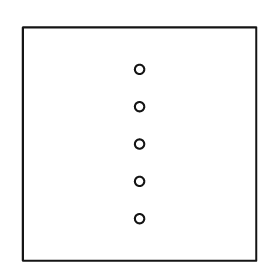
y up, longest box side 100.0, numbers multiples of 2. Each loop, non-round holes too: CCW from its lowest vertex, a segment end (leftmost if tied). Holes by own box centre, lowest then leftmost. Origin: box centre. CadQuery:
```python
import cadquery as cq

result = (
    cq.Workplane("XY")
    .moveTo(-50.0, -50.0)
    .lineTo(50.0, -50.0)
    .lineTo(50.0, 50.0)
    .lineTo(-50.0, 50.0)
    .close()
    .moveTo(0.0, -32.0)
    .circle(2.0)
    .moveTo(0.0, -16.0)
    .circle(2.0)
    .moveTo(0.0, 0.0)
    .circle(2.0)
    .moveTo(0.0, 16.0)
    .circle(2.0)
    .moveTo(0.0, 32.0)
    .circle(2.0)
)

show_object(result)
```